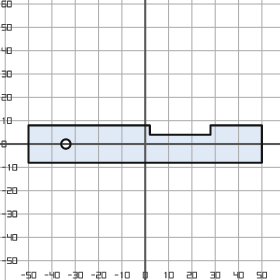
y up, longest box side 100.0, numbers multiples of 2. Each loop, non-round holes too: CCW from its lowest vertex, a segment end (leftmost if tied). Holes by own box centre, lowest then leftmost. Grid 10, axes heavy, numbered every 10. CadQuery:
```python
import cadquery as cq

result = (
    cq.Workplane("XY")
    .moveTo(-50.0, -8.0)
    .lineTo(50.0, -8.0)
    .lineTo(50.0, 8.0)
    .lineTo(28.0, 8.0)
    .lineTo(28.0, 4.0)
    .lineTo(2.0, 4.0)
    .lineTo(2.0, 8.0)
    .lineTo(-50.0, 8.0)
    .close()
    .moveTo(-34.0, 0.0)
    .circle(2.0)
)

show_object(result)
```